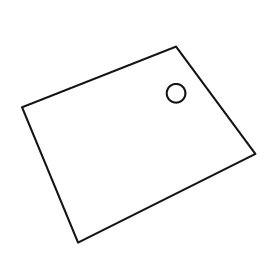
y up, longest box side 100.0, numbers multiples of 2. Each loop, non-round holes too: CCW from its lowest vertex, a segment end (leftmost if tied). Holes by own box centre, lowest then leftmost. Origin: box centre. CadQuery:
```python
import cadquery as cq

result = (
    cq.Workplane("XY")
    .moveTo(-26.0, -42.0)
    .lineTo(50.0, -4.0)
    .lineTo(16.0, 42.0)
    .lineTo(-50.0, 16.0)
    .close()
    .moveTo(16.0, 22.0)
    .circle(4.0)
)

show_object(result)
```